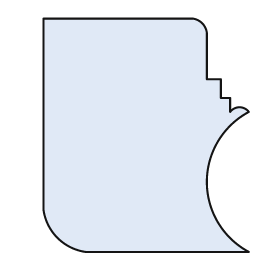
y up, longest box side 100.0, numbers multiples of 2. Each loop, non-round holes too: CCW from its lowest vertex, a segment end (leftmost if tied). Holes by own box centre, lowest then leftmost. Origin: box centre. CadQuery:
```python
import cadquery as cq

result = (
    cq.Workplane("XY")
    .moveTo(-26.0, -50.0)
    .lineTo(44.0, -50.0)
    .threePointArc((26.0, -20.0), (44.0, 10.0))
    .threePointArc((40.0, 12.0), (36.0, 10.0))
    .lineTo(36.0, 16.0)
    .lineTo(32.0, 16.0)
    .lineTo(32.0, 24.0)
    .lineTo(26.0, 24.0)
    .lineTo(26.0, 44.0)
    .threePointArc((24.0, 48.0), (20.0, 50.0))
    .lineTo(-44.0, 50.0)
    .lineTo(-44.0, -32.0)
    .threePointArc((-38.0, -44.0), (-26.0, -50.0))
    .close()
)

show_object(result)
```